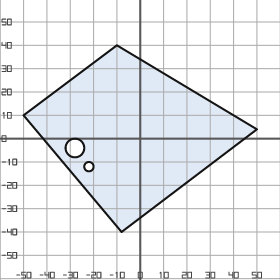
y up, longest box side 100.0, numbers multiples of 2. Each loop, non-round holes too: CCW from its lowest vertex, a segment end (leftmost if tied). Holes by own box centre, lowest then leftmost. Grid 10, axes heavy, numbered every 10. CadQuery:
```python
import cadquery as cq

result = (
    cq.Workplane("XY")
    .moveTo(-8.0, -40.0)
    .lineTo(50.0, 4.0)
    .lineTo(-10.0, 40.0)
    .lineTo(-50.0, 10.0)
    .close()
    .moveTo(-22.0, -12.0)
    .circle(2.0)
    .moveTo(-28.0, -4.0)
    .circle(4.0)
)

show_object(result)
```